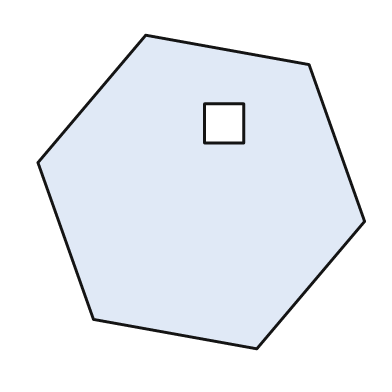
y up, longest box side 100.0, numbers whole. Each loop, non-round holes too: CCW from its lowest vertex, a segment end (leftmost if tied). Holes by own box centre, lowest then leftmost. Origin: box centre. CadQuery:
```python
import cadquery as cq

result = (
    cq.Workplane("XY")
    .moveTo(17.0, -48.0)
    .lineTo(50.0, -9.0)
    .lineTo(33.0, 39.0)
    .lineTo(-17.0, 48.0)
    .lineTo(-50.0, 9.0)
    .lineTo(-33.0, -39.0)
    .close()
    .moveTo(1.0, 15.0)
    .lineTo(13.0, 15.0)
    .lineTo(13.0, 27.0)
    .lineTo(1.0, 27.0)
    .close()
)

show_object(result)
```